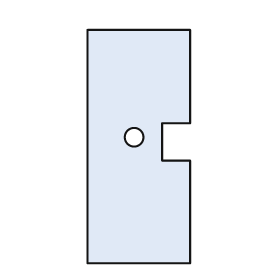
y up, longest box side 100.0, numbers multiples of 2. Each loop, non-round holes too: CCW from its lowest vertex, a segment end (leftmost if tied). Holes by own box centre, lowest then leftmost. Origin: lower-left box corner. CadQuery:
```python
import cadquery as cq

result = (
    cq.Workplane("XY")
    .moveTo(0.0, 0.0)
    .lineTo(44.0, 0.0)
    .lineTo(44.0, 44.0)
    .lineTo(32.0, 44.0)
    .lineTo(32.0, 60.0)
    .lineTo(44.0, 60.0)
    .lineTo(44.0, 100.0)
    .lineTo(0.0, 100.0)
    .close()
    .moveTo(20.0, 54.0)
    .circle(4.0)
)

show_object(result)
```